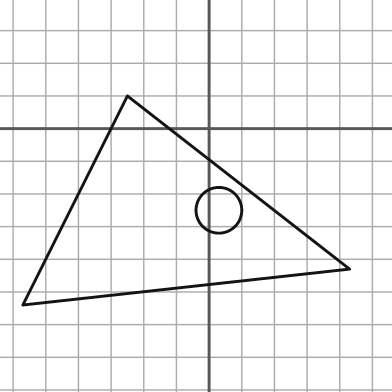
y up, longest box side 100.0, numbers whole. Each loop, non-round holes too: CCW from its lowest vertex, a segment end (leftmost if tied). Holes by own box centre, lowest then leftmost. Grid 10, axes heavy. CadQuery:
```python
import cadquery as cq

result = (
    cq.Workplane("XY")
    .moveTo(-57.0, -54.0)
    .lineTo(43.0, -43.0)
    .lineTo(-25.0, 10.0)
    .close()
    .moveTo(3.0, -25.0)
    .circle(7.0)
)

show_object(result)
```